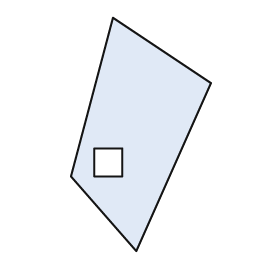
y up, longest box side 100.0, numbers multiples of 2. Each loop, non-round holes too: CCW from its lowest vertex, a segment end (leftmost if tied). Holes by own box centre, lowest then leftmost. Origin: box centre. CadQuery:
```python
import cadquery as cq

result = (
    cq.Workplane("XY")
    .moveTo(-2.0, -50.0)
    .lineTo(30.0, 22.0)
    .lineTo(-12.0, 50.0)
    .lineTo(-30.0, -18.0)
    .close()
    .moveTo(-20.0, -18.0)
    .lineTo(-8.0, -18.0)
    .lineTo(-8.0, -6.0)
    .lineTo(-20.0, -6.0)
    .close()
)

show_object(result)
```